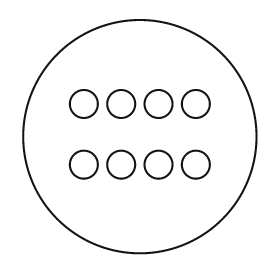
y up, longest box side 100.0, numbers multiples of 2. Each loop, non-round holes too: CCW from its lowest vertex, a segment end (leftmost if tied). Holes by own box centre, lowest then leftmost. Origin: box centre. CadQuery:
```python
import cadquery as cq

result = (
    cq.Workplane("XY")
    .moveTo(0.0, 0.0)
    .circle(50.0)
    .moveTo(-24.0, -12.0)
    .circle(6.0)
    .moveTo(-8.0, -12.0)
    .circle(6.0)
    .moveTo(8.0, -12.0)
    .circle(6.0)
    .moveTo(24.0, -12.0)
    .circle(6.0)
    .moveTo(-24.0, 14.0)
    .circle(6.0)
    .moveTo(-8.0, 14.0)
    .circle(6.0)
    .moveTo(8.0, 14.0)
    .circle(6.0)
    .moveTo(24.0, 14.0)
    .circle(6.0)
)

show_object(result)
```